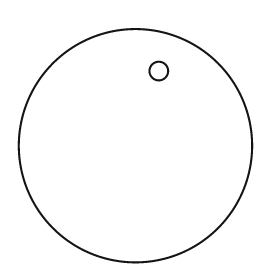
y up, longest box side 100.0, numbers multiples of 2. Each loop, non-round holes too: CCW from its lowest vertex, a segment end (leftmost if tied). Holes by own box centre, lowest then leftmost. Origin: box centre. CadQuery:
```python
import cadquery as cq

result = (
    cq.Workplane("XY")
    .moveTo(0.0, 0.0)
    .circle(50.0)
    .moveTo(10.0, 32.0)
    .circle(4.0)
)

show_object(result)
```